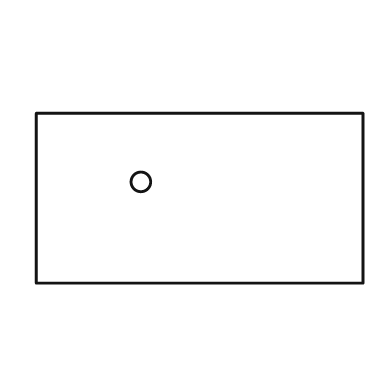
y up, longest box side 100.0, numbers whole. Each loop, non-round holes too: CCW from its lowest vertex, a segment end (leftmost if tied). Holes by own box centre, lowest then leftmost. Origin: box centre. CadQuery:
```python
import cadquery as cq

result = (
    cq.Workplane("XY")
    .moveTo(-50.0, -26.0)
    .lineTo(50.0, -26.0)
    .lineTo(50.0, 26.0)
    .lineTo(-50.0, 26.0)
    .close()
    .moveTo(-18.0, 5.0)
    .circle(3.0)
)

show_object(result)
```